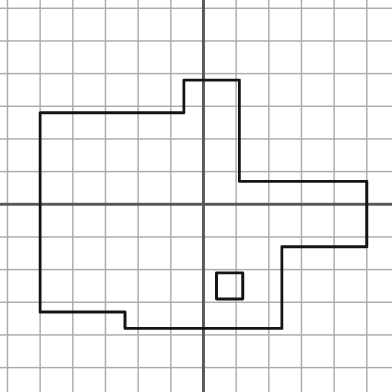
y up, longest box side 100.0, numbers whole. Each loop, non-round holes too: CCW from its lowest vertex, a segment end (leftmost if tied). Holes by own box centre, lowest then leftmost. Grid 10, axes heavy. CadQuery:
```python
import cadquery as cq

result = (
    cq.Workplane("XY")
    .moveTo(-24.0, -38.0)
    .lineTo(24.0, -38.0)
    .lineTo(24.0, -13.0)
    .lineTo(50.0, -13.0)
    .lineTo(50.0, 7.0)
    .lineTo(11.0, 7.0)
    .lineTo(11.0, 38.0)
    .lineTo(-6.0, 38.0)
    .lineTo(-6.0, 28.0)
    .lineTo(-50.0, 28.0)
    .lineTo(-50.0, -33.0)
    .lineTo(-24.0, -33.0)
    .close()
    .moveTo(4.0, -29.0)
    .lineTo(12.0, -29.0)
    .lineTo(12.0, -21.0)
    .lineTo(4.0, -21.0)
    .close()
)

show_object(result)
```